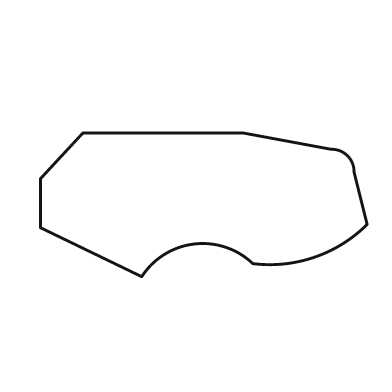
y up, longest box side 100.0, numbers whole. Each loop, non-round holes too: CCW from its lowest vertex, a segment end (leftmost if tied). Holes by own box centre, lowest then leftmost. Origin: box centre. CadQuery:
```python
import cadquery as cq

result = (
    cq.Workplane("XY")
    .moveTo(-19.0, -22.0)
    .threePointArc((-3.0, -12.0), (15.0, -18.0))
    .threePointArc((34.0, -16.0), (50.0, -6.0))
    .lineTo(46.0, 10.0)
    .threePointArc((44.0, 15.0), (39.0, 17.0))
    .lineTo(12.0, 22.0)
    .lineTo(-37.0, 22.0)
    .lineTo(-50.0, 8.0)
    .lineTo(-50.0, -7.0)
    .close()
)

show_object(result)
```